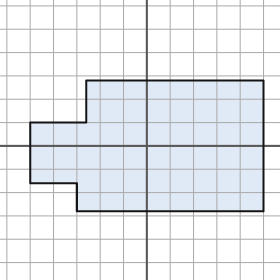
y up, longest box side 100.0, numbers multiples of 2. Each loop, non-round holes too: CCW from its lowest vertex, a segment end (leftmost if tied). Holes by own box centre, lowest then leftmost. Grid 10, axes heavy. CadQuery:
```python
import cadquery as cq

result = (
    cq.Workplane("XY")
    .moveTo(-30.0, -28.0)
    .lineTo(50.0, -28.0)
    .lineTo(50.0, 28.0)
    .lineTo(-26.0, 28.0)
    .lineTo(-26.0, 10.0)
    .lineTo(-50.0, 10.0)
    .lineTo(-50.0, -16.0)
    .lineTo(-30.0, -16.0)
    .close()
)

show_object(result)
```